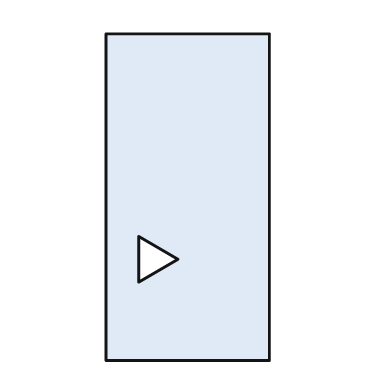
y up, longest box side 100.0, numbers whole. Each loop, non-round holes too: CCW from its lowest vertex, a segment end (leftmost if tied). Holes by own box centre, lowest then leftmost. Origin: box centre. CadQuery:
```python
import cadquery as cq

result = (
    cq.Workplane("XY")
    .moveTo(-25.0, -50.0)
    .lineTo(25.0, -50.0)
    .lineTo(25.0, 50.0)
    .lineTo(-25.0, 50.0)
    .close()
    .moveTo(-15.0, -26.0)
    .lineTo(-3.0, -19.0)
    .lineTo(-15.0, -12.0)
    .close()
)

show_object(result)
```